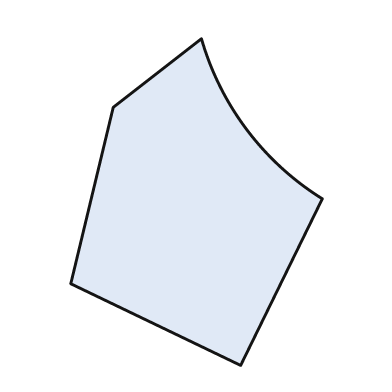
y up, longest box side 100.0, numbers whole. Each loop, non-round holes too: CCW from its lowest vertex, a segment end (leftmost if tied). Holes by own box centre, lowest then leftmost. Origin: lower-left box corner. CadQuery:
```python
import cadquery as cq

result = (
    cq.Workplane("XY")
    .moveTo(52.0, 0.0)
    .lineTo(77.0, 51.0)
    .threePointArc((54.0, 72.0), (40.0, 100.0))
    .lineTo(13.0, 79.0)
    .lineTo(0.0, 25.0)
    .close()
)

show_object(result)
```